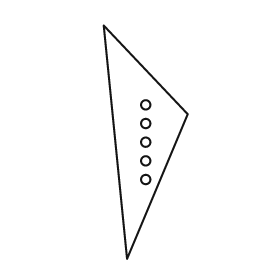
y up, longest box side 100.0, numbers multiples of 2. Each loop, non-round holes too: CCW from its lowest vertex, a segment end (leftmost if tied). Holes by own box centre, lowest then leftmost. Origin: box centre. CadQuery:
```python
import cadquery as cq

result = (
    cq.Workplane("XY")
    .moveTo(-8.0, -50.0)
    .lineTo(18.0, 12.0)
    .lineTo(-18.0, 50.0)
    .close()
    .moveTo(0.0, -16.0)
    .circle(2.0)
    .moveTo(0.0, -8.0)
    .circle(2.0)
    .moveTo(0.0, 0.0)
    .circle(2.0)
    .moveTo(0.0, 8.0)
    .circle(2.0)
    .moveTo(0.0, 16.0)
    .circle(2.0)
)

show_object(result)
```